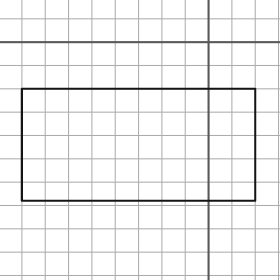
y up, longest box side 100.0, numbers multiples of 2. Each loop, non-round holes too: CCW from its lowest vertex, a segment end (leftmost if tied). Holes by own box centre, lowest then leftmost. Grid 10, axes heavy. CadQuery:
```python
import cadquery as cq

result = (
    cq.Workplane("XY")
    .moveTo(-80.0, -68.0)
    .lineTo(20.0, -68.0)
    .lineTo(20.0, -20.0)
    .lineTo(-80.0, -20.0)
    .close()
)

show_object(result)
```